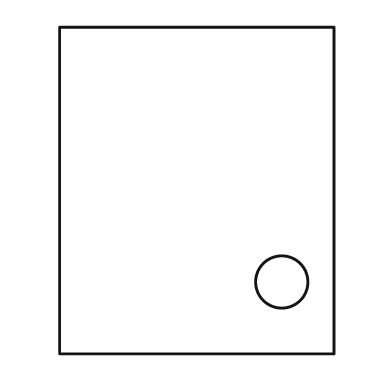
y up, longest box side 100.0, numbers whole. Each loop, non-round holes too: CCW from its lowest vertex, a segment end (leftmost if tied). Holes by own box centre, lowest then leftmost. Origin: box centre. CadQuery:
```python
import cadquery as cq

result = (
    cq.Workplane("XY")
    .moveTo(-42.0, -50.0)
    .lineTo(42.0, -50.0)
    .lineTo(42.0, 50.0)
    .lineTo(-42.0, 50.0)
    .close()
    .moveTo(26.0, -28.0)
    .circle(8.0)
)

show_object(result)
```